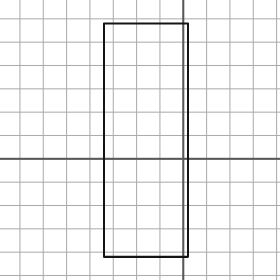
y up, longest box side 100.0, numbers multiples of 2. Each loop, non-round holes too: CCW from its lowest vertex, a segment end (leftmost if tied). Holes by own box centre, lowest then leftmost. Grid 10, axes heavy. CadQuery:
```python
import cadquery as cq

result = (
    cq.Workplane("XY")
    .moveTo(-34.0, -42.0)
    .lineTo(2.0, -42.0)
    .lineTo(2.0, 58.0)
    .lineTo(-34.0, 58.0)
    .close()
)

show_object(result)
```